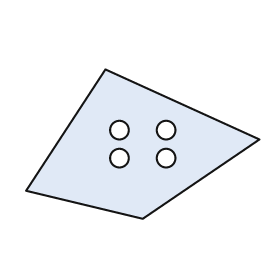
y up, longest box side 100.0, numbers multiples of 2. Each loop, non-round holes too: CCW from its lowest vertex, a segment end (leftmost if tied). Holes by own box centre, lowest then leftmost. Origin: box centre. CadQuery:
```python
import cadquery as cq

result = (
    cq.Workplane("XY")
    .moveTo(0.0, -32.0)
    .lineTo(50.0, 2.0)
    .lineTo(-16.0, 32.0)
    .lineTo(-50.0, -20.0)
    .close()
    .moveTo(-10.0, -6.0)
    .circle(4.0)
    .moveTo(10.0, -6.0)
    .circle(4.0)
    .moveTo(-10.0, 6.0)
    .circle(4.0)
    .moveTo(10.0, 6.0)
    .circle(4.0)
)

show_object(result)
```